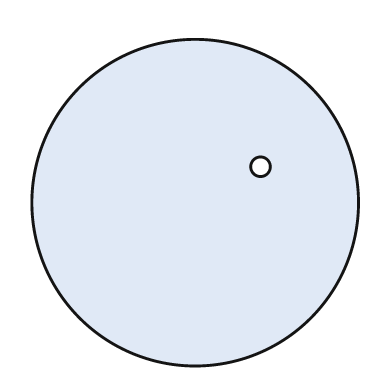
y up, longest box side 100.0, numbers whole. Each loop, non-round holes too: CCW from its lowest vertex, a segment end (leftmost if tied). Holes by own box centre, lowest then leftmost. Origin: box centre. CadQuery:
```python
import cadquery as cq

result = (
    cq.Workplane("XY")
    .moveTo(0.0, 0.0)
    .circle(50.0)
    .moveTo(20.0, 11.0)
    .circle(3.0)
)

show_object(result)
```